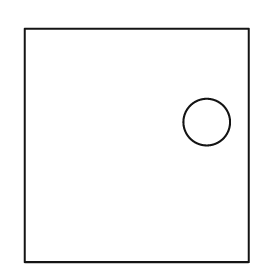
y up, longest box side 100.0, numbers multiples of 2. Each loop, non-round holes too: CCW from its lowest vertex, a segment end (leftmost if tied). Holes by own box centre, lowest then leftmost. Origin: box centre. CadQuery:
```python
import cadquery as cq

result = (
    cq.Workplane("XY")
    .moveTo(-48.0, -50.0)
    .lineTo(48.0, -50.0)
    .lineTo(48.0, 50.0)
    .lineTo(-48.0, 50.0)
    .close()
    .moveTo(30.0, 10.0)
    .circle(10.0)
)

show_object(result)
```